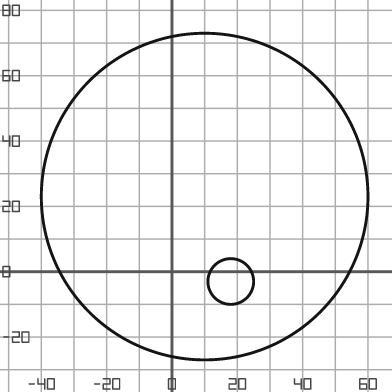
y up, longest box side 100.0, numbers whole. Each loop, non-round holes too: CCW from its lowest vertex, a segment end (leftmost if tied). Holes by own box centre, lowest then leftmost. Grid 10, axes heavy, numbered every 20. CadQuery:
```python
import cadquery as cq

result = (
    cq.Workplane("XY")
    .moveTo(10.0, 23.0)
    .circle(50.0)
    .moveTo(18.0, -3.0)
    .circle(7.0)
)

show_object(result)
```